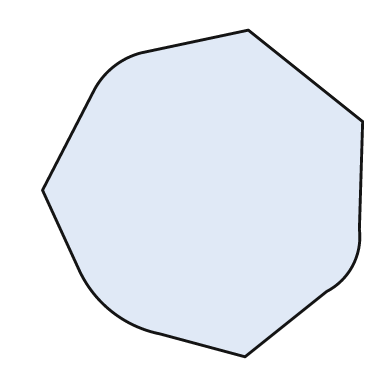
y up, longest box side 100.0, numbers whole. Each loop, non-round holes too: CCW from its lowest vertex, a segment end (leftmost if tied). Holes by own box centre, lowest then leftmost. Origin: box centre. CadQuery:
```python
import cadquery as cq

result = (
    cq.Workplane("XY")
    .moveTo(13.0, -50.0)
    .lineTo(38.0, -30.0)
    .threePointArc((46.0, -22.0), (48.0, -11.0))
    .lineTo(49.0, 22.0)
    .lineTo(14.0, 50.0)
    .lineTo(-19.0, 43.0)
    .threePointArc((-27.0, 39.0), (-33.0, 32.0))
    .lineTo(-49.0, 1.0)
    .lineTo(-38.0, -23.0)
    .threePointArc((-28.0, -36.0), (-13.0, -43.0))
    .close()
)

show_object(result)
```